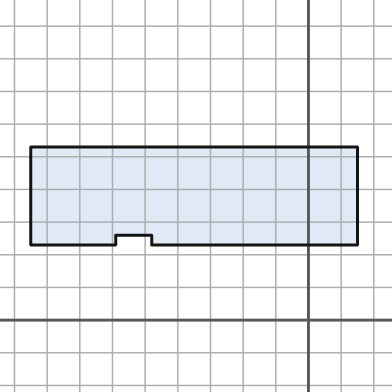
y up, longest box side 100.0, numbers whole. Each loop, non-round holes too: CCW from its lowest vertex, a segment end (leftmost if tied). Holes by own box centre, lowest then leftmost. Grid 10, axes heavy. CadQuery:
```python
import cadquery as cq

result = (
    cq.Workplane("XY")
    .moveTo(-85.0, 23.0)
    .lineTo(-59.0, 23.0)
    .lineTo(-59.0, 26.0)
    .lineTo(-48.0, 26.0)
    .lineTo(-48.0, 23.0)
    .lineTo(15.0, 23.0)
    .lineTo(15.0, 53.0)
    .lineTo(-85.0, 53.0)
    .close()
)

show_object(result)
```